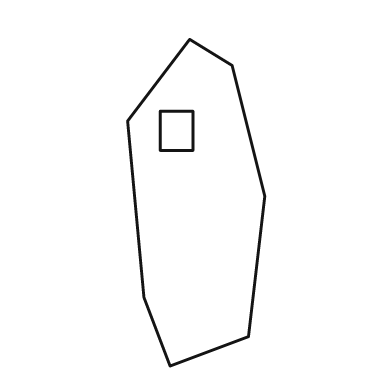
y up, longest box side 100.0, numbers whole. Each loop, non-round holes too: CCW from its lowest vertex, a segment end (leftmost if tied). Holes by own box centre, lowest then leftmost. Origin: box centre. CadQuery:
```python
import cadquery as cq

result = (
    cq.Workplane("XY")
    .moveTo(-8.0, -50.0)
    .lineTo(16.0, -41.0)
    .lineTo(21.0, 2.0)
    .lineTo(11.0, 42.0)
    .lineTo(-2.0, 50.0)
    .lineTo(-21.0, 25.0)
    .lineTo(-16.0, -29.0)
    .close()
    .moveTo(-11.0, 16.0)
    .lineTo(-1.0, 16.0)
    .lineTo(-1.0, 28.0)
    .lineTo(-11.0, 28.0)
    .close()
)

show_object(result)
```